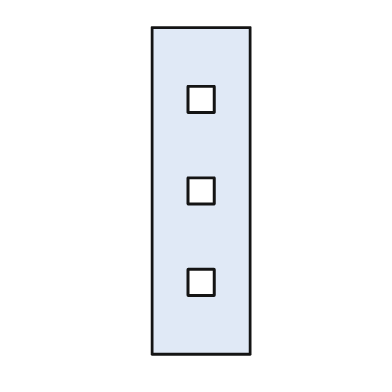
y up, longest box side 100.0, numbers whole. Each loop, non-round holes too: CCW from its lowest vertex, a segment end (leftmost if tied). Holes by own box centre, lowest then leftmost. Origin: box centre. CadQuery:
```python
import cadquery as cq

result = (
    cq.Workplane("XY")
    .moveTo(-15.0, -50.0)
    .lineTo(15.0, -50.0)
    .lineTo(15.0, 50.0)
    .lineTo(-15.0, 50.0)
    .close()
    .moveTo(-4.0, -32.0)
    .lineTo(4.0, -32.0)
    .lineTo(4.0, -24.0)
    .lineTo(-4.0, -24.0)
    .close()
    .moveTo(-4.0, -4.0)
    .lineTo(4.0, -4.0)
    .lineTo(4.0, 4.0)
    .lineTo(-4.0, 4.0)
    .close()
    .moveTo(-4.0, 24.0)
    .lineTo(4.0, 24.0)
    .lineTo(4.0, 32.0)
    .lineTo(-4.0, 32.0)
    .close()
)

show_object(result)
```